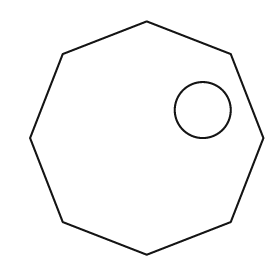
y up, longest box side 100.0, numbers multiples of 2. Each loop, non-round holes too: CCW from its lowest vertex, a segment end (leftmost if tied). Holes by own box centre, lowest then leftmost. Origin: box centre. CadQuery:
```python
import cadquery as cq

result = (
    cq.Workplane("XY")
    .moveTo(0.0, -50.0)
    .lineTo(36.0, -36.0)
    .lineTo(50.0, 0.0)
    .lineTo(36.0, 36.0)
    .lineTo(0.0, 50.0)
    .lineTo(-36.0, 36.0)
    .lineTo(-50.0, 0.0)
    .lineTo(-36.0, -36.0)
    .close()
    .moveTo(24.0, 12.0)
    .circle(12.0)
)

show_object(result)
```